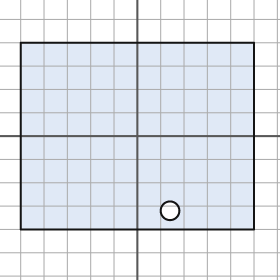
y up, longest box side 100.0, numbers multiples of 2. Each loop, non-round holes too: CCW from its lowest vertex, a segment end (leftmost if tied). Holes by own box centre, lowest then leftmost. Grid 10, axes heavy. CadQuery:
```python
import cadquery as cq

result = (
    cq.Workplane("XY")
    .moveTo(-50.0, -40.0)
    .lineTo(50.0, -40.0)
    .lineTo(50.0, 40.0)
    .lineTo(-50.0, 40.0)
    .close()
    .moveTo(14.0, -32.0)
    .circle(4.0)
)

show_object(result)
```